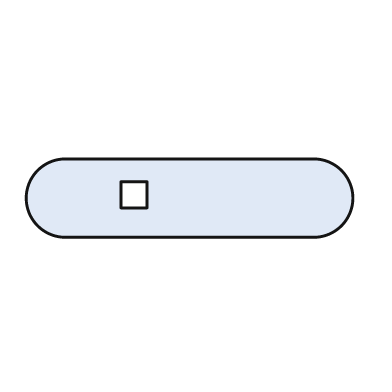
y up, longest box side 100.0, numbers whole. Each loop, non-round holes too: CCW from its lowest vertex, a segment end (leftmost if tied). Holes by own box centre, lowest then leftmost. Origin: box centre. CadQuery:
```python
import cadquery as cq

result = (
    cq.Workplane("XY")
    .moveTo(-38.0, -12.0)
    .lineTo(38.0, -12.0)
    .threePointArc((50.0, 0.0), (38.0, 12.0))
    .lineTo(-38.0, 12.0)
    .threePointArc((-50.0, 0.0), (-38.0, -12.0))
    .close()
    .moveTo(-21.0, -3.0)
    .lineTo(-13.0, -3.0)
    .lineTo(-13.0, 5.0)
    .lineTo(-21.0, 5.0)
    .close()
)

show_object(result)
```